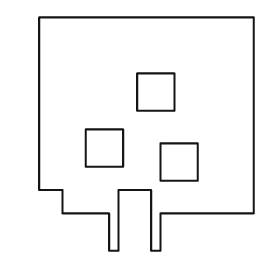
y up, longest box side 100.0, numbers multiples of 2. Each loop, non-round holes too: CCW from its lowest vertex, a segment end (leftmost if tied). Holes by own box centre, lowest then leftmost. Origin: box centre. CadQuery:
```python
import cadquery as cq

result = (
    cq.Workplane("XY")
    .moveTo(-16.0, -50.0)
    .lineTo(-12.0, -50.0)
    .lineTo(-12.0, -24.0)
    .lineTo(2.0, -24.0)
    .lineTo(2.0, -50.0)
    .lineTo(6.0, -50.0)
    .lineTo(6.0, -34.0)
    .lineTo(46.0, -34.0)
    .lineTo(46.0, 50.0)
    .lineTo(-46.0, 50.0)
    .lineTo(-46.0, -24.0)
    .lineTo(-36.0, -24.0)
    .lineTo(-36.0, -34.0)
    .lineTo(-16.0, -34.0)
    .close()
    .moveTo(6.0, -20.0)
    .lineTo(22.0, -20.0)
    .lineTo(22.0, -4.0)
    .lineTo(6.0, -4.0)
    .close()
    .moveTo(-26.0, -14.0)
    .lineTo(-10.0, -14.0)
    .lineTo(-10.0, 2.0)
    .lineTo(-26.0, 2.0)
    .close()
    .moveTo(-4.0, 10.0)
    .lineTo(12.0, 10.0)
    .lineTo(12.0, 26.0)
    .lineTo(-4.0, 26.0)
    .close()
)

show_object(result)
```